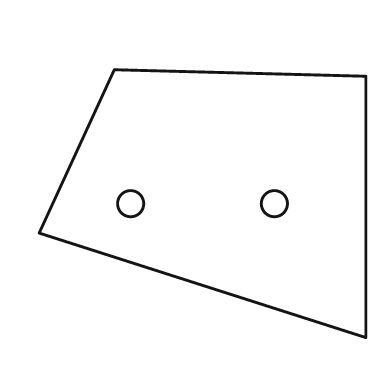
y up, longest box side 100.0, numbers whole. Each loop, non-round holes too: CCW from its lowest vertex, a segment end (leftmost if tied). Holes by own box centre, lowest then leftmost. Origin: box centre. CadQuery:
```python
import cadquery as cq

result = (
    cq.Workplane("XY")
    .moveTo(50.0, -41.0)
    .lineTo(50.0, 39.0)
    .lineTo(-27.0, 41.0)
    .lineTo(-50.0, -9.0)
    .close()
    .moveTo(-22.0, 0.0)
    .circle(4.0)
    .moveTo(22.0, 0.0)
    .circle(4.0)
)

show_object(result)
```